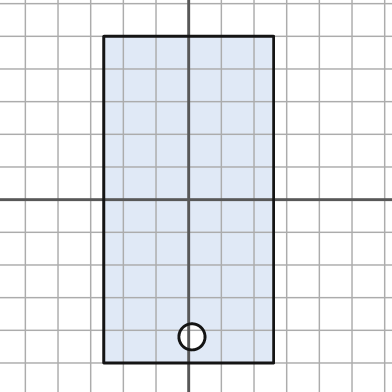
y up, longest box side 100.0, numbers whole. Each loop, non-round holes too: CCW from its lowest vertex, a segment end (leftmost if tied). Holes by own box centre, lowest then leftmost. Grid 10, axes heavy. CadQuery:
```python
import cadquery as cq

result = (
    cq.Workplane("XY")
    .moveTo(-26.0, -50.0)
    .lineTo(26.0, -50.0)
    .lineTo(26.0, 50.0)
    .lineTo(-26.0, 50.0)
    .close()
    .moveTo(1.0, -42.0)
    .circle(4.0)
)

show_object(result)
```